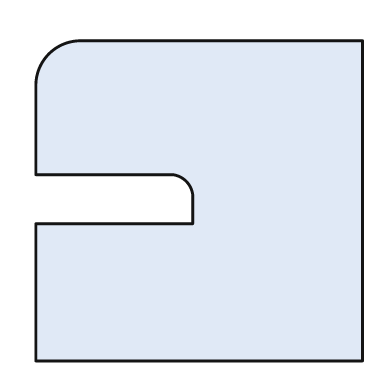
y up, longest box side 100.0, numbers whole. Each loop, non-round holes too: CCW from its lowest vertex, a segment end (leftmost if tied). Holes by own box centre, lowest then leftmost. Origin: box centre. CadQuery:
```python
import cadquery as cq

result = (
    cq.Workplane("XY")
    .moveTo(-50.0, -49.0)
    .lineTo(50.0, -49.0)
    .lineTo(50.0, 49.0)
    .lineTo(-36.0, 49.0)
    .threePointArc((-46.0, 45.0), (-50.0, 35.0))
    .lineTo(-50.0, 8.0)
    .lineTo(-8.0, 8.0)
    .threePointArc((-4.0, 6.0), (-2.0, 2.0))
    .lineTo(-2.0, -7.0)
    .lineTo(-50.0, -7.0)
    .close()
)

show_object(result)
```